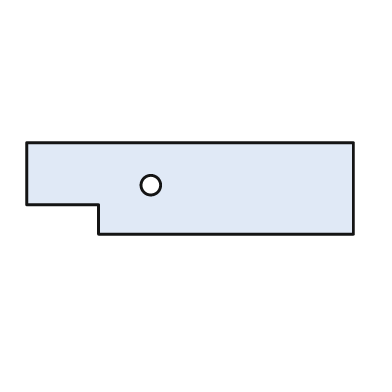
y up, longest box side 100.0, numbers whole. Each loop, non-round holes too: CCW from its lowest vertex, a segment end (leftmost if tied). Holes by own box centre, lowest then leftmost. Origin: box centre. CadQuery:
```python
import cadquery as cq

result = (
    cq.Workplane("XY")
    .moveTo(-28.0, -14.0)
    .lineTo(50.0, -14.0)
    .lineTo(50.0, 14.0)
    .lineTo(-50.0, 14.0)
    .lineTo(-50.0, -5.0)
    .lineTo(-28.0, -5.0)
    .close()
    .moveTo(-12.0, 1.0)
    .circle(3.0)
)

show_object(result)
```